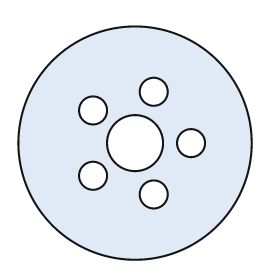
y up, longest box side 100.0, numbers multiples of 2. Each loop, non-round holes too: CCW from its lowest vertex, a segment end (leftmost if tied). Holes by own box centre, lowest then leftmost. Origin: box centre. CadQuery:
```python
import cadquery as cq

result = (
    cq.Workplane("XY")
    .moveTo(0.0, 0.0)
    .circle(50.0)
    .moveTo(8.0, -22.0)
    .circle(6.0)
    .moveTo(-18.0, -14.0)
    .circle(6.0)
    .moveTo(0.0, 0.0)
    .circle(12.0)
    .moveTo(24.0, 0.0)
    .circle(6.0)
    .moveTo(-18.0, 14.0)
    .circle(6.0)
    .moveTo(8.0, 22.0)
    .circle(6.0)
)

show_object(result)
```